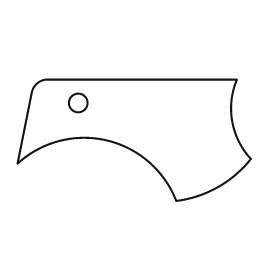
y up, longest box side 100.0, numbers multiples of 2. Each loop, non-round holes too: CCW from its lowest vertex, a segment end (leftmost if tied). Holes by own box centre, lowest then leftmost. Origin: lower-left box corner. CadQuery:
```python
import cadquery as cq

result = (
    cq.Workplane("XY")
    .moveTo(68.0, 0.0)
    .threePointArc((86.0, 6.0), (100.0, 18.0))
    .threePointArc((92.0, 34.0), (94.0, 52.0))
    .lineTo(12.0, 52.0)
    .threePointArc((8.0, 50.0), (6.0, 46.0))
    .lineTo(0.0, 16.0)
    .threePointArc((38.0, 26.0), (68.0, 0.0))
    .close()
    .moveTo(26.0, 42.0)
    .circle(4.0)
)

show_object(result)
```